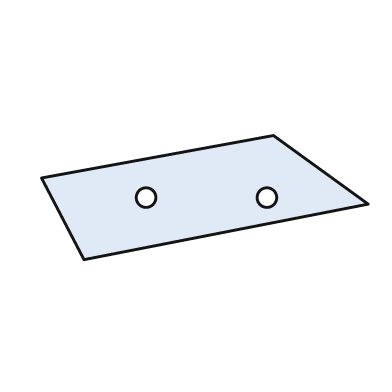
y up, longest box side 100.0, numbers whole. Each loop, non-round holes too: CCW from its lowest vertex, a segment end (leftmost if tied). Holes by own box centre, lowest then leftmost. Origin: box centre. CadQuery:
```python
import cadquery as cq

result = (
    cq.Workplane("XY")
    .moveTo(-37.0, -19.0)
    .lineTo(50.0, -2.0)
    .lineTo(21.0, 19.0)
    .lineTo(-50.0, 6.0)
    .close()
    .moveTo(-18.0, 0.0)
    .circle(3.0)
    .moveTo(19.0, 0.0)
    .circle(3.0)
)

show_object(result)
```